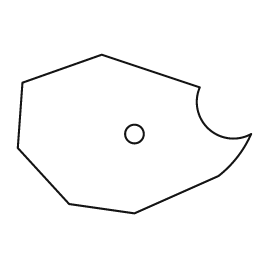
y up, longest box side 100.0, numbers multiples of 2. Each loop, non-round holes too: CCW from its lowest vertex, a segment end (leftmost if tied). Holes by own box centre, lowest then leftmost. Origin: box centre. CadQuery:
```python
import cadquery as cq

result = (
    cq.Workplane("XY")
    .moveTo(0.0, -34.0)
    .lineTo(36.0, -18.0)
    .threePointArc((44.0, -10.0), (50.0, 0.0))
    .threePointArc((32.0, 2.0), (28.0, 20.0))
    .lineTo(-14.0, 34.0)
    .lineTo(-48.0, 22.0)
    .lineTo(-50.0, -6.0)
    .lineTo(-28.0, -30.0)
    .close()
    .moveTo(0.0, 0.0)
    .circle(4.0)
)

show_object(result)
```